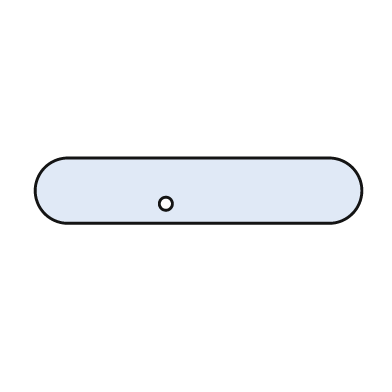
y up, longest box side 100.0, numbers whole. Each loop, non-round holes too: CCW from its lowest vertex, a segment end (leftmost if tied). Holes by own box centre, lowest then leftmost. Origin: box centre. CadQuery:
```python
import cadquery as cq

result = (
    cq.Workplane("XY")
    .moveTo(-40.0, -10.0)
    .lineTo(40.0, -10.0)
    .threePointArc((50.0, 0.0), (40.0, 10.0))
    .lineTo(-40.0, 10.0)
    .threePointArc((-50.0, 0.0), (-40.0, -10.0))
    .close()
    .moveTo(-10.0, -4.0)
    .circle(2.0)
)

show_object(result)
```